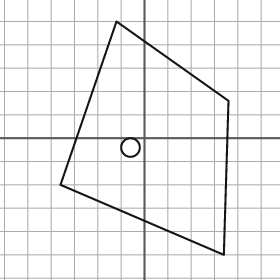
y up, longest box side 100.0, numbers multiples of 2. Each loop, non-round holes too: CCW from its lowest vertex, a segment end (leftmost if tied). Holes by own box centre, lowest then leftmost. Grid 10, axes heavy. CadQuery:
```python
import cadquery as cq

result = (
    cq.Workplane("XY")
    .moveTo(34.0, -50.0)
    .lineTo(36.0, 16.0)
    .lineTo(-12.0, 50.0)
    .lineTo(-36.0, -20.0)
    .close()
    .moveTo(-6.0, -4.0)
    .circle(4.0)
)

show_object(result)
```